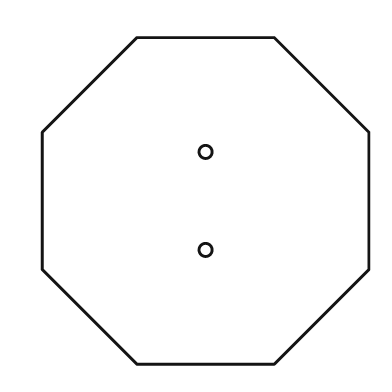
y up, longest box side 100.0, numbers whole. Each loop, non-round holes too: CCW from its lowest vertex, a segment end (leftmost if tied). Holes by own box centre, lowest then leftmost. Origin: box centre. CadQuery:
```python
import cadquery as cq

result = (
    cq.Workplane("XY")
    .moveTo(-21.0, -50.0)
    .lineTo(21.0, -50.0)
    .lineTo(50.0, -21.0)
    .lineTo(50.0, 21.0)
    .lineTo(21.0, 50.0)
    .lineTo(-21.0, 50.0)
    .lineTo(-50.0, 21.0)
    .lineTo(-50.0, -21.0)
    .close()
    .moveTo(0.0, -15.0)
    .circle(2.0)
    .moveTo(0.0, 15.0)
    .circle(2.0)
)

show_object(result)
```